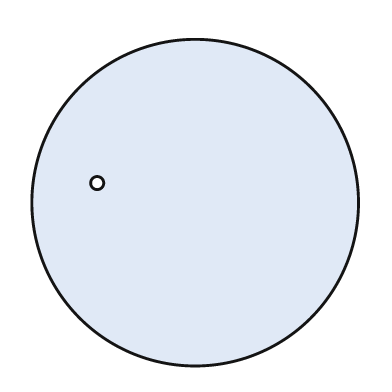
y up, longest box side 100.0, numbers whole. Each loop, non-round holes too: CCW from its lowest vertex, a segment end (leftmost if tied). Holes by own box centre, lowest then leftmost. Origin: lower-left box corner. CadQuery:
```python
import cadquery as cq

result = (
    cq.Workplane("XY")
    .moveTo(50.0, 50.0)
    .circle(50.0)
    .moveTo(20.0, 56.0)
    .circle(2.0)
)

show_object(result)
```